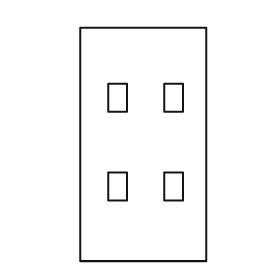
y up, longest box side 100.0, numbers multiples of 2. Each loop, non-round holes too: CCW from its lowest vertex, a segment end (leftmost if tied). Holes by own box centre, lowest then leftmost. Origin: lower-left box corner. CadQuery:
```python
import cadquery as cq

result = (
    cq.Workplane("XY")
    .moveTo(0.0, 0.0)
    .lineTo(54.0, 0.0)
    .lineTo(54.0, 100.0)
    .lineTo(0.0, 100.0)
    .close()
    .moveTo(12.0, 26.0)
    .lineTo(20.0, 26.0)
    .lineTo(20.0, 38.0)
    .lineTo(12.0, 38.0)
    .close()
    .moveTo(36.0, 26.0)
    .lineTo(44.0, 26.0)
    .lineTo(44.0, 38.0)
    .lineTo(36.0, 38.0)
    .close()
    .moveTo(12.0, 64.0)
    .lineTo(20.0, 64.0)
    .lineTo(20.0, 76.0)
    .lineTo(12.0, 76.0)
    .close()
    .moveTo(36.0, 64.0)
    .lineTo(44.0, 64.0)
    .lineTo(44.0, 76.0)
    .lineTo(36.0, 76.0)
    .close()
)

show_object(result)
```